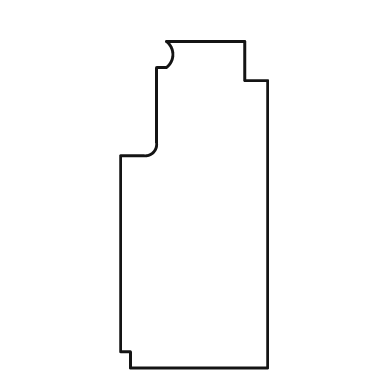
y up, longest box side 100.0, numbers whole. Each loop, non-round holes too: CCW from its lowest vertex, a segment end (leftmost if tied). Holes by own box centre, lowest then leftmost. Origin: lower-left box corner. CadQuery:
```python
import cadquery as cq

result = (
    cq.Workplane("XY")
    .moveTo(3.0, 0.0)
    .lineTo(45.0, 0.0)
    .lineTo(45.0, 88.0)
    .lineTo(38.0, 88.0)
    .lineTo(38.0, 100.0)
    .lineTo(14.0, 100.0)
    .threePointArc((16.0, 96.0), (14.0, 92.0))
    .lineTo(11.0, 92.0)
    .lineTo(11.0, 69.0)
    .threePointArc((10.0, 66.0), (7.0, 65.0))
    .lineTo(0.0, 65.0)
    .lineTo(0.0, 5.0)
    .lineTo(3.0, 5.0)
    .close()
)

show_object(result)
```